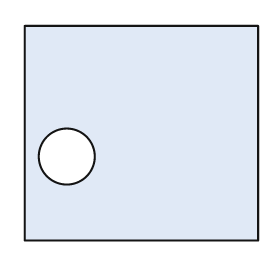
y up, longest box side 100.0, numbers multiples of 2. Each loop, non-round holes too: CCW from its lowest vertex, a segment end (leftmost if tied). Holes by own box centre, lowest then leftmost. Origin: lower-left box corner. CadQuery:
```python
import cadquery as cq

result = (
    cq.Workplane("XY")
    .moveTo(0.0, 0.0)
    .lineTo(100.0, 0.0)
    .lineTo(100.0, 92.0)
    .lineTo(0.0, 92.0)
    .close()
    .moveTo(18.0, 36.0)
    .circle(12.0)
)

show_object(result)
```